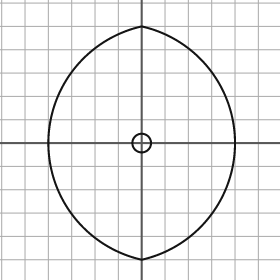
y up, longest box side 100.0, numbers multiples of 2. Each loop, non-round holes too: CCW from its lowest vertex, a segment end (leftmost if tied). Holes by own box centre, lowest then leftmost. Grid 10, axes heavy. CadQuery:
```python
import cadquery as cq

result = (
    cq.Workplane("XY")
    .moveTo(0.0, -50.0)
    .threePointArc((40.0, 0.0), (0.0, 50.0))
    .threePointArc((-40.0, 0.0), (0.0, -50.0))
    .close()
    .moveTo(0.0, 0.0)
    .circle(4.0)
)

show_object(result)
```